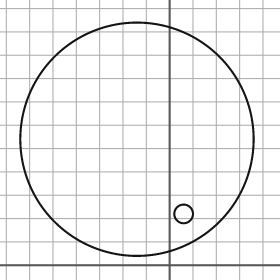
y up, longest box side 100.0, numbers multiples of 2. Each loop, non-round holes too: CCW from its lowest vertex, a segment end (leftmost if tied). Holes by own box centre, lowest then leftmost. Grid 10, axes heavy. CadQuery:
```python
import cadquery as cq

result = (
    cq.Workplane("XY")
    .moveTo(-14.0, 54.0)
    .circle(50.0)
    .moveTo(6.0, 22.0)
    .circle(4.0)
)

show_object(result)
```